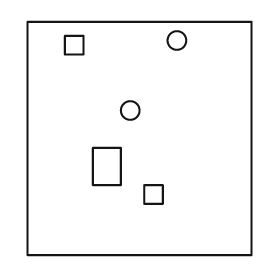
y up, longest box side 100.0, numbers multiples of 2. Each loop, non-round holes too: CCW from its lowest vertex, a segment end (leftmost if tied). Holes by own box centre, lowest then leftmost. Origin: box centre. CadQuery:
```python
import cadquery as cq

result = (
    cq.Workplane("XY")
    .moveTo(-48.0, -50.0)
    .lineTo(48.0, -50.0)
    .lineTo(48.0, 50.0)
    .lineTo(-48.0, 50.0)
    .close()
    .moveTo(2.0, -28.0)
    .lineTo(10.0, -28.0)
    .lineTo(10.0, -20.0)
    .lineTo(2.0, -20.0)
    .close()
    .moveTo(-20.0, -20.0)
    .lineTo(-8.0, -20.0)
    .lineTo(-8.0, -4.0)
    .lineTo(-20.0, -4.0)
    .close()
    .moveTo(-4.0, 12.0)
    .circle(4.0)
    .moveTo(-32.0, 36.0)
    .lineTo(-24.0, 36.0)
    .lineTo(-24.0, 44.0)
    .lineTo(-32.0, 44.0)
    .close()
    .moveTo(16.0, 42.0)
    .circle(4.0)
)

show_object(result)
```